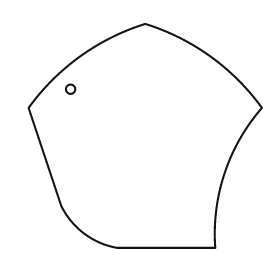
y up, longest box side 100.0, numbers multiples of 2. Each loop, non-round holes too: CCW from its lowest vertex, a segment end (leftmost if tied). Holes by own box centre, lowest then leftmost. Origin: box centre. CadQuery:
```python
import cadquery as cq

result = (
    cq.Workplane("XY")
    .moveTo(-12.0, -48.0)
    .lineTo(30.0, -48.0)
    .threePointArc((34.0, -16.0), (50.0, 12.0))
    .threePointArc((28.0, 34.0), (0.0, 48.0))
    .threePointArc((-28.0, 34.0), (-50.0, 12.0))
    .lineTo(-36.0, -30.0)
    .threePointArc((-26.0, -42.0), (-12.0, -48.0))
    .close()
    .moveTo(-32.0, 20.0)
    .circle(2.0)
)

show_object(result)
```